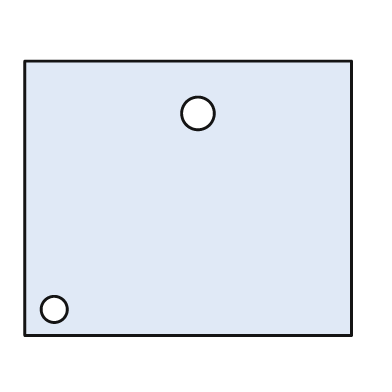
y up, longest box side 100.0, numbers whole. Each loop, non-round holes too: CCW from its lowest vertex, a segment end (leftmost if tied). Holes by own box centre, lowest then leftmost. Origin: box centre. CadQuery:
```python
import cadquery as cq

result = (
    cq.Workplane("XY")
    .moveTo(-50.0, -42.0)
    .lineTo(50.0, -42.0)
    .lineTo(50.0, 42.0)
    .lineTo(-50.0, 42.0)
    .close()
    .moveTo(-41.0, -34.0)
    .circle(4.0)
    .moveTo(3.0, 26.0)
    .circle(5.0)
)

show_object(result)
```